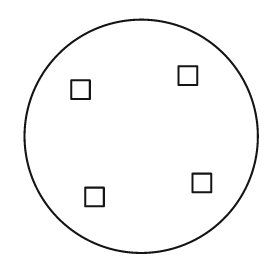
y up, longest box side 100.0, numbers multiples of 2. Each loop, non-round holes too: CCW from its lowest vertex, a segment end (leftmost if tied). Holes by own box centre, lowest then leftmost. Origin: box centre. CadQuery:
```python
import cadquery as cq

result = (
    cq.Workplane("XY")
    .moveTo(0.0, 0.0)
    .circle(50.0)
    .moveTo(-24.0, -30.0)
    .lineTo(-16.0, -30.0)
    .lineTo(-16.0, -22.0)
    .lineTo(-24.0, -22.0)
    .close()
    .moveTo(22.0, -24.0)
    .lineTo(30.0, -24.0)
    .lineTo(30.0, -16.0)
    .lineTo(22.0, -16.0)
    .close()
    .moveTo(-30.0, 16.0)
    .lineTo(-22.0, 16.0)
    .lineTo(-22.0, 24.0)
    .lineTo(-30.0, 24.0)
    .close()
    .moveTo(16.0, 22.0)
    .lineTo(24.0, 22.0)
    .lineTo(24.0, 30.0)
    .lineTo(16.0, 30.0)
    .close()
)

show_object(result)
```